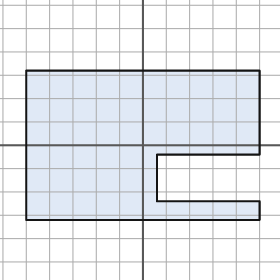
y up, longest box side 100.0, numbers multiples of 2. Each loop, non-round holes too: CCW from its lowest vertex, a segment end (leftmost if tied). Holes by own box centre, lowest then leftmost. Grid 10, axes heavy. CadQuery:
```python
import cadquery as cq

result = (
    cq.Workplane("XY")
    .moveTo(-50.0, -32.0)
    .lineTo(50.0, -32.0)
    .lineTo(50.0, -24.0)
    .lineTo(6.0, -24.0)
    .lineTo(6.0, -4.0)
    .lineTo(50.0, -4.0)
    .lineTo(50.0, 32.0)
    .lineTo(-50.0, 32.0)
    .close()
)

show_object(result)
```